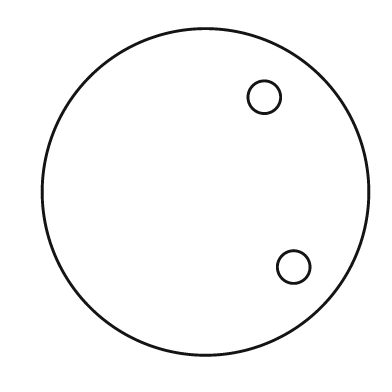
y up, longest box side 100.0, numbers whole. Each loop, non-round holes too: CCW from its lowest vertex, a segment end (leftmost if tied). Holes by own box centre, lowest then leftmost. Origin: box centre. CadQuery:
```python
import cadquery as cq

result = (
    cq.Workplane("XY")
    .moveTo(0.0, 0.0)
    .circle(50.0)
    .moveTo(27.0, -23.0)
    .circle(5.0)
    .moveTo(18.0, 29.0)
    .circle(5.0)
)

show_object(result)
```